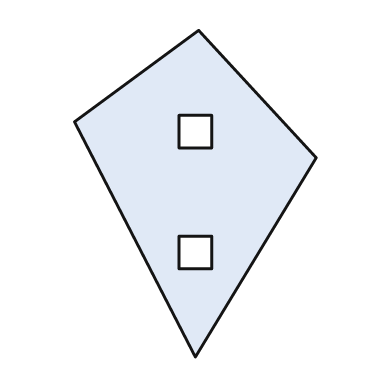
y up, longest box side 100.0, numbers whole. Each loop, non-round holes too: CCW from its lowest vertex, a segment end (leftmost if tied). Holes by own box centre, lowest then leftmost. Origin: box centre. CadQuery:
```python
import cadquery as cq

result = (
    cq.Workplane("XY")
    .moveTo(0.0, -50.0)
    .lineTo(37.0, 11.0)
    .lineTo(1.0, 50.0)
    .lineTo(-37.0, 22.0)
    .close()
    .moveTo(-5.0, -23.0)
    .lineTo(5.0, -23.0)
    .lineTo(5.0, -13.0)
    .lineTo(-5.0, -13.0)
    .close()
    .moveTo(-5.0, 14.0)
    .lineTo(5.0, 14.0)
    .lineTo(5.0, 24.0)
    .lineTo(-5.0, 24.0)
    .close()
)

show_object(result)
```